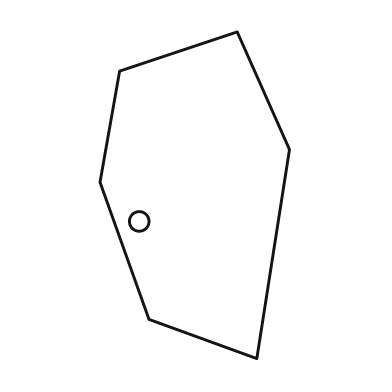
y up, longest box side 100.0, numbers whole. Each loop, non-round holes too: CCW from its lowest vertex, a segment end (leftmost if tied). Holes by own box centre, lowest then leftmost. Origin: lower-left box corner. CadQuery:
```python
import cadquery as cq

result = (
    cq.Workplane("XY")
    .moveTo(48.0, 0.0)
    .lineTo(58.0, 64.0)
    .lineTo(42.0, 100.0)
    .lineTo(6.0, 88.0)
    .lineTo(0.0, 54.0)
    .lineTo(15.0, 12.0)
    .close()
    .moveTo(12.0, 42.0)
    .circle(3.0)
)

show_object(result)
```